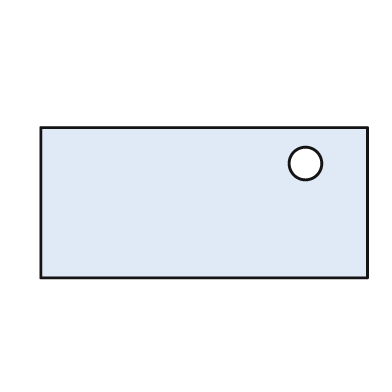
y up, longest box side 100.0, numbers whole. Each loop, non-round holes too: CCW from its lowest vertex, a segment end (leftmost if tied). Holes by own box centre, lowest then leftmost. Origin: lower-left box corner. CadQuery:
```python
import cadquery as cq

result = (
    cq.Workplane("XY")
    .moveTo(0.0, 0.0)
    .lineTo(100.0, 0.0)
    .lineTo(100.0, 46.0)
    .lineTo(0.0, 46.0)
    .close()
    .moveTo(81.0, 35.0)
    .circle(5.0)
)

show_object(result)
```